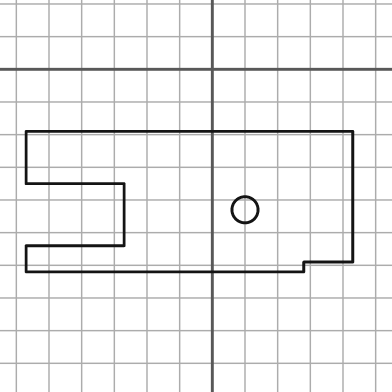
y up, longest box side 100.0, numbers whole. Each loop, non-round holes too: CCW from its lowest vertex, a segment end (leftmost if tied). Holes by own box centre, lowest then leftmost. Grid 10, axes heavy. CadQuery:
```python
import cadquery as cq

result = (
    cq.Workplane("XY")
    .moveTo(-57.0, -62.0)
    .lineTo(28.0, -62.0)
    .lineTo(28.0, -59.0)
    .lineTo(43.0, -59.0)
    .lineTo(43.0, -19.0)
    .lineTo(-57.0, -19.0)
    .lineTo(-57.0, -35.0)
    .lineTo(-27.0, -35.0)
    .lineTo(-27.0, -54.0)
    .lineTo(-57.0, -54.0)
    .close()
    .moveTo(10.0, -43.0)
    .circle(4.0)
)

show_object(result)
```